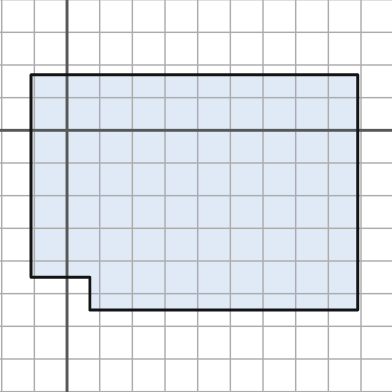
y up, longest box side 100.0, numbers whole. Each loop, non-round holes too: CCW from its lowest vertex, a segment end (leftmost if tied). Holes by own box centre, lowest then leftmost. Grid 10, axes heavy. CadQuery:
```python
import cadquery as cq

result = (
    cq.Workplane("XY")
    .moveTo(7.0, -55.0)
    .lineTo(89.0, -55.0)
    .lineTo(89.0, 17.0)
    .lineTo(-11.0, 17.0)
    .lineTo(-11.0, -45.0)
    .lineTo(7.0, -45.0)
    .close()
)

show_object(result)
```